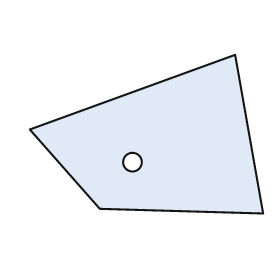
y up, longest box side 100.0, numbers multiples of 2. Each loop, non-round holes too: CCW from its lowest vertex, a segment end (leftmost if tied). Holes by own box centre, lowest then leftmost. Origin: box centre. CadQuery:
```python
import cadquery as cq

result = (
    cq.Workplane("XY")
    .moveTo(50.0, -34.0)
    .lineTo(38.0, 34.0)
    .lineTo(-50.0, 2.0)
    .lineTo(-20.0, -32.0)
    .close()
    .moveTo(-6.0, -12.0)
    .circle(4.0)
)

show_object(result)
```